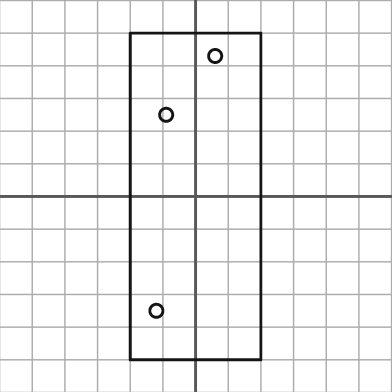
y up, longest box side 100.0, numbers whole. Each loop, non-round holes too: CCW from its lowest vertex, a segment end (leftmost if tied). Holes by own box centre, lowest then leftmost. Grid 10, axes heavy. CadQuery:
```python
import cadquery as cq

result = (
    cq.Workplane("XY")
    .moveTo(-20.0, -50.0)
    .lineTo(20.0, -50.0)
    .lineTo(20.0, 50.0)
    .lineTo(-20.0, 50.0)
    .close()
    .moveTo(-12.0, -35.0)
    .circle(2.0)
    .moveTo(-9.0, 25.0)
    .circle(2.0)
    .moveTo(6.0, 43.0)
    .circle(2.0)
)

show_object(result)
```